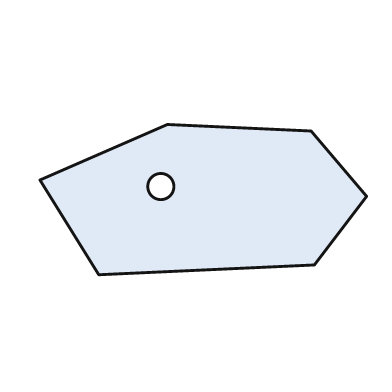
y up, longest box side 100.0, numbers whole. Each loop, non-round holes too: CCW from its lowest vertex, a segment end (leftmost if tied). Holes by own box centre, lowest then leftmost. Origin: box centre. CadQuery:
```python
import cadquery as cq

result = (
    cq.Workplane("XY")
    .moveTo(-32.0, -23.0)
    .lineTo(34.0, -20.0)
    .lineTo(50.0, 1.0)
    .lineTo(33.0, 21.0)
    .lineTo(-11.0, 23.0)
    .lineTo(-50.0, 6.0)
    .close()
    .moveTo(-13.0, 4.0)
    .circle(4.0)
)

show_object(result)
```